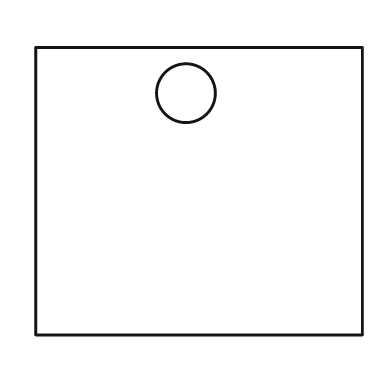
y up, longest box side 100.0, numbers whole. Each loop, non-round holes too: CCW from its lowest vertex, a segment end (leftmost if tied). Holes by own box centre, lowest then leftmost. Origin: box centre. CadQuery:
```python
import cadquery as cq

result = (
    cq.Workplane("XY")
    .moveTo(-50.0, -44.0)
    .lineTo(50.0, -44.0)
    .lineTo(50.0, 44.0)
    .lineTo(-50.0, 44.0)
    .close()
    .moveTo(-4.0, 30.0)
    .circle(9.0)
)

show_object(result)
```